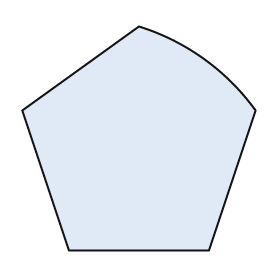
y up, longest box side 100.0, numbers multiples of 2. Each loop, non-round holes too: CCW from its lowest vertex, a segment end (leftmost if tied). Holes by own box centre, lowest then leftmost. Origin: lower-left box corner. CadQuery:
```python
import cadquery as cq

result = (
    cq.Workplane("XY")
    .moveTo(20.0, 0.0)
    .lineTo(80.0, 0.0)
    .lineTo(100.0, 60.0)
    .threePointArc((78.0, 82.0), (50.0, 96.0))
    .lineTo(0.0, 60.0)
    .close()
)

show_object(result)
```